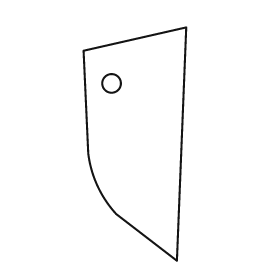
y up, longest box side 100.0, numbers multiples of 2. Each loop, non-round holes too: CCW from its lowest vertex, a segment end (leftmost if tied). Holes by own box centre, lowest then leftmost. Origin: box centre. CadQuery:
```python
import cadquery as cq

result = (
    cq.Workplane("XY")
    .moveTo(18.0, -50.0)
    .lineTo(22.0, 50.0)
    .lineTo(-22.0, 40.0)
    .lineTo(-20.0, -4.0)
    .threePointArc((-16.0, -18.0), (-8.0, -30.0))
    .close()
    .moveTo(-10.0, 26.0)
    .circle(4.0)
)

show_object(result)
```